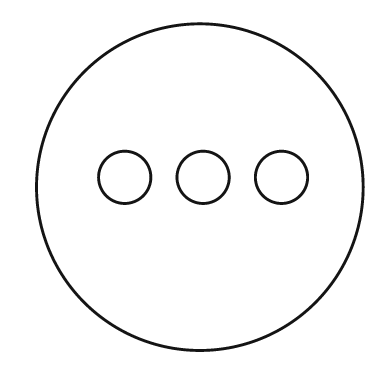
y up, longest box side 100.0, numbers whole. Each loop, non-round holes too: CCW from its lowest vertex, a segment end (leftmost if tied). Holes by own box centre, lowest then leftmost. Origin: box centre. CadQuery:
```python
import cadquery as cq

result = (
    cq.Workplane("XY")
    .moveTo(0.0, 0.0)
    .circle(50.0)
    .moveTo(-23.0, 3.0)
    .circle(8.0)
    .moveTo(1.0, 3.0)
    .circle(8.0)
    .moveTo(25.0, 3.0)
    .circle(8.0)
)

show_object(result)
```